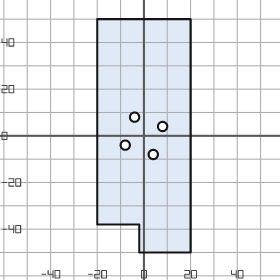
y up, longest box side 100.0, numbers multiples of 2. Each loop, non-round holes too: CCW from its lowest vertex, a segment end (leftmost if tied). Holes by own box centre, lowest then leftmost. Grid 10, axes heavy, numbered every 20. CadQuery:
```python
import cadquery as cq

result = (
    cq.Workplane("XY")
    .moveTo(-2.0, -50.0)
    .lineTo(20.0, -50.0)
    .lineTo(20.0, 50.0)
    .lineTo(-20.0, 50.0)
    .lineTo(-20.0, -38.0)
    .lineTo(-2.0, -38.0)
    .close()
    .moveTo(4.0, -8.0)
    .circle(2.0)
    .moveTo(-8.0, -4.0)
    .circle(2.0)
    .moveTo(8.0, 4.0)
    .circle(2.0)
    .moveTo(-4.0, 8.0)
    .circle(2.0)
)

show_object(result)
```